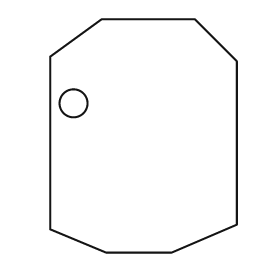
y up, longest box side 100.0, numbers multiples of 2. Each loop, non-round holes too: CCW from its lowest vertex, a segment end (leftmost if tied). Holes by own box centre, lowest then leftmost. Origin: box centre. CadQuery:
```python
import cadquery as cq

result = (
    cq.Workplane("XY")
    .moveTo(-16.0, -50.0)
    .lineTo(12.0, -50.0)
    .lineTo(40.0, -38.0)
    .lineTo(40.0, 32.0)
    .lineTo(22.0, 50.0)
    .lineTo(-18.0, 50.0)
    .lineTo(-40.0, 34.0)
    .lineTo(-40.0, -40.0)
    .close()
    .moveTo(-30.0, 14.0)
    .circle(6.0)
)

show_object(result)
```